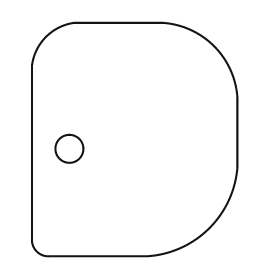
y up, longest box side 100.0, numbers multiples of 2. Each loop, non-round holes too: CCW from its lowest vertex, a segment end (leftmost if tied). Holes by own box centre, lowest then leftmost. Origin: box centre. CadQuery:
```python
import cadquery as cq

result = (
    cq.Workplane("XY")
    .moveTo(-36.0, -50.0)
    .lineTo(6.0, -50.0)
    .threePointArc((32.0, -38.0), (44.0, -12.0))
    .lineTo(44.0, 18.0)
    .threePointArc((34.0, 40.0), (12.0, 50.0))
    .lineTo(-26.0, 50.0)
    .threePointArc((-38.0, 44.0), (-44.0, 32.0))
    .lineTo(-44.0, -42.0)
    .threePointArc((-42.0, -48.0), (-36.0, -50.0))
    .close()
    .moveTo(-28.0, -4.0)
    .circle(6.0)
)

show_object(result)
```